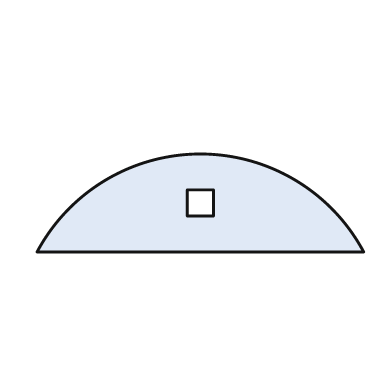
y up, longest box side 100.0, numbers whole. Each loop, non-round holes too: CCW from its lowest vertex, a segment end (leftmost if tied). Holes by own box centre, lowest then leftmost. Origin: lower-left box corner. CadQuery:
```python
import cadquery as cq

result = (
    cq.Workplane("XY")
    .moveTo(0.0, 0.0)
    .lineTo(100.0, 0.0)
    .threePointArc((50.0, 30.0), (0.0, 0.0))
    .close()
    .moveTo(46.0, 11.0)
    .lineTo(54.0, 11.0)
    .lineTo(54.0, 19.0)
    .lineTo(46.0, 19.0)
    .close()
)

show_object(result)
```